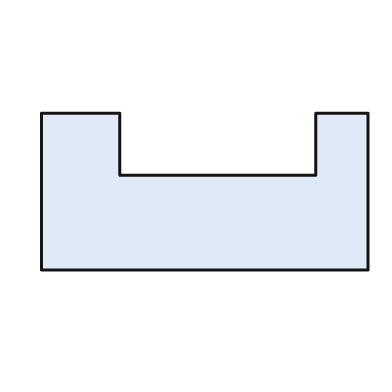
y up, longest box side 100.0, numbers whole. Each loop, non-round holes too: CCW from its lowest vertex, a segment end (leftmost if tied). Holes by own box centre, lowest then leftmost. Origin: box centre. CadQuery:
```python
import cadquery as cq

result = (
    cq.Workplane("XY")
    .moveTo(-50.0, -24.0)
    .lineTo(50.0, -24.0)
    .lineTo(50.0, 24.0)
    .lineTo(34.0, 24.0)
    .lineTo(34.0, 5.0)
    .lineTo(-26.0, 5.0)
    .lineTo(-26.0, 24.0)
    .lineTo(-50.0, 24.0)
    .close()
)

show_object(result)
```